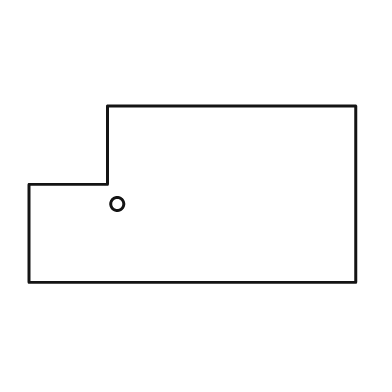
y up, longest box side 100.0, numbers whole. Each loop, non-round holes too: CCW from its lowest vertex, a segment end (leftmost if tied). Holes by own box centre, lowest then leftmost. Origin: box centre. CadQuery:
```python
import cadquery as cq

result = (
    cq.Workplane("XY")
    .moveTo(-50.0, -27.0)
    .lineTo(50.0, -27.0)
    .lineTo(50.0, 27.0)
    .lineTo(-26.0, 27.0)
    .lineTo(-26.0, 3.0)
    .lineTo(-50.0, 3.0)
    .close()
    .moveTo(-23.0, -3.0)
    .circle(2.0)
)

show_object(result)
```